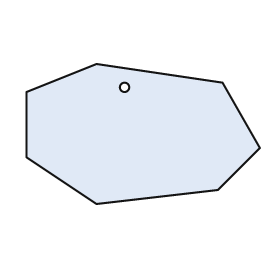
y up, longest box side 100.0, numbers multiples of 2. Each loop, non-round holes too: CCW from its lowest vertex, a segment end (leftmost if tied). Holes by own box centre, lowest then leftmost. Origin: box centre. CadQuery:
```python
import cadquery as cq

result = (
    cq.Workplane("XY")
    .moveTo(-20.0, -30.0)
    .lineTo(32.0, -24.0)
    .lineTo(50.0, -6.0)
    .lineTo(34.0, 22.0)
    .lineTo(-20.0, 30.0)
    .lineTo(-50.0, 18.0)
    .lineTo(-50.0, -10.0)
    .close()
    .moveTo(-8.0, 20.0)
    .circle(2.0)
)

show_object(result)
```